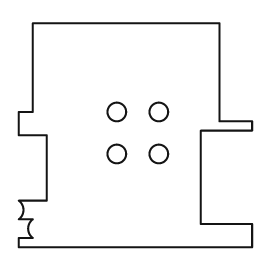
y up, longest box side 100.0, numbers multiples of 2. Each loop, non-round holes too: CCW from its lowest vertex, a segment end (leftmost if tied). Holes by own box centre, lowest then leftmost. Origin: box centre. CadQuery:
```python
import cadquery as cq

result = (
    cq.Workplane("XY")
    .moveTo(-50.0, -48.0)
    .lineTo(50.0, -48.0)
    .lineTo(50.0, -38.0)
    .lineTo(28.0, -38.0)
    .lineTo(28.0, 2.0)
    .lineTo(50.0, 2.0)
    .lineTo(50.0, 6.0)
    .lineTo(36.0, 6.0)
    .lineTo(36.0, 48.0)
    .lineTo(-44.0, 48.0)
    .lineTo(-44.0, 10.0)
    .lineTo(-50.0, 10.0)
    .lineTo(-50.0, 0.0)
    .lineTo(-38.0, 0.0)
    .lineTo(-38.0, -28.0)
    .lineTo(-50.0, -28.0)
    .threePointArc((-48.0, -32.0), (-50.0, -36.0))
    .lineTo(-44.0, -36.0)
    .threePointArc((-46.0, -40.0), (-44.0, -44.0))
    .lineTo(-50.0, -44.0)
    .close()
    .moveTo(-8.0, -8.0)
    .circle(4.0)
    .moveTo(10.0, -8.0)
    .circle(4.0)
    .moveTo(-8.0, 10.0)
    .circle(4.0)
    .moveTo(10.0, 10.0)
    .circle(4.0)
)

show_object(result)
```